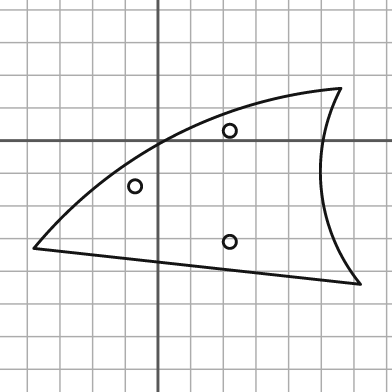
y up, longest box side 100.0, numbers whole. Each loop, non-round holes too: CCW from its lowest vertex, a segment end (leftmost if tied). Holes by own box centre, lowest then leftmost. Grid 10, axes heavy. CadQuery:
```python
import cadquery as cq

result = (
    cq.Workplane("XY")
    .moveTo(62.0, -44.0)
    .threePointArc((50.0, -15.0), (56.0, 16.0))
    .threePointArc((4.0, 1.0), (-38.0, -33.0))
    .close()
    .moveTo(22.0, -31.0)
    .circle(2.0)
    .moveTo(-7.0, -14.0)
    .circle(2.0)
    .moveTo(22.0, 3.0)
    .circle(2.0)
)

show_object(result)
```